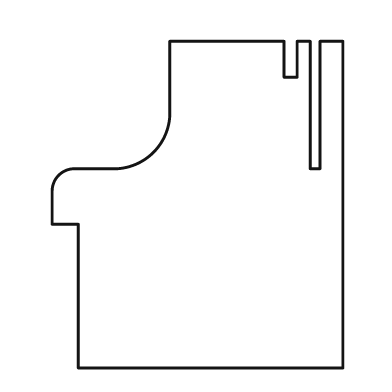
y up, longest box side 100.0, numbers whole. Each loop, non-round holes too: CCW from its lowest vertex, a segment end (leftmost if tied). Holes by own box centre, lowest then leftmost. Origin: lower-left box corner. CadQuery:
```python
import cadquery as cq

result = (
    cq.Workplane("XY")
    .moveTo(8.0, 0.0)
    .lineTo(89.0, 0.0)
    .lineTo(89.0, 100.0)
    .lineTo(82.0, 100.0)
    .lineTo(82.0, 61.0)
    .lineTo(79.0, 61.0)
    .lineTo(79.0, 100.0)
    .lineTo(75.0, 100.0)
    .lineTo(75.0, 89.0)
    .lineTo(71.0, 89.0)
    .lineTo(71.0, 100.0)
    .lineTo(36.0, 100.0)
    .lineTo(36.0, 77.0)
    .threePointArc((31.0, 66.0), (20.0, 61.0))
    .lineTo(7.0, 61.0)
    .threePointArc((2.0, 59.0), (0.0, 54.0))
    .lineTo(0.0, 44.0)
    .lineTo(8.0, 44.0)
    .close()
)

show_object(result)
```